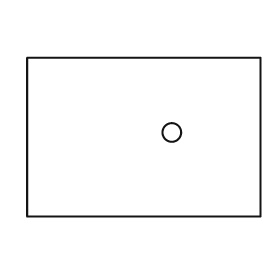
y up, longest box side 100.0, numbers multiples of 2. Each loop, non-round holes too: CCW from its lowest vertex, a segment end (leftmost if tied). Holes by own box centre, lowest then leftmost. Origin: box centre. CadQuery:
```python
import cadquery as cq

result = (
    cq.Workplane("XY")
    .moveTo(-50.0, -34.0)
    .lineTo(50.0, -34.0)
    .lineTo(50.0, 34.0)
    .lineTo(-50.0, 34.0)
    .close()
    .moveTo(12.0, 2.0)
    .circle(4.0)
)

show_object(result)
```